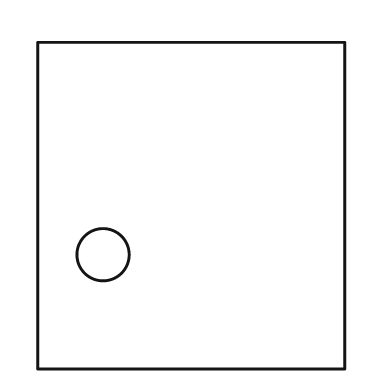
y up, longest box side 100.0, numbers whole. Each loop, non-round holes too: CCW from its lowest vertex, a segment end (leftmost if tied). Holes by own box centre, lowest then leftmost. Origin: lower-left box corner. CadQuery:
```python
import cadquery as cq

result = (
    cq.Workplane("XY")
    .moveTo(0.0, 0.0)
    .lineTo(94.0, 0.0)
    .lineTo(94.0, 100.0)
    .lineTo(0.0, 100.0)
    .close()
    .moveTo(20.0, 35.0)
    .circle(8.0)
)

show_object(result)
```